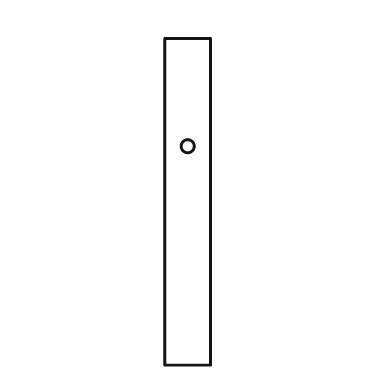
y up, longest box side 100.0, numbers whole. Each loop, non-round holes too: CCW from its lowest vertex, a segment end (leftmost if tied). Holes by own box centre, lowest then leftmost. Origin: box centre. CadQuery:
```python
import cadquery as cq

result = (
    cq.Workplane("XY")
    .moveTo(-7.0, -50.0)
    .lineTo(7.0, -50.0)
    .lineTo(7.0, 50.0)
    .lineTo(-7.0, 50.0)
    .close()
    .moveTo(0.0, 17.0)
    .circle(2.0)
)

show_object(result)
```